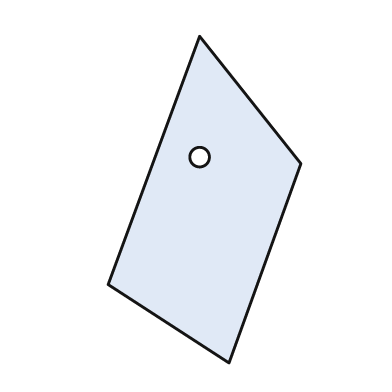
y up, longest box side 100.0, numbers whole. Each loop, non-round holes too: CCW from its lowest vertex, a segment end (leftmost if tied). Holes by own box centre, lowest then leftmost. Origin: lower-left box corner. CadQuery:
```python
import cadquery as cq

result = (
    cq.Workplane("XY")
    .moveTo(37.0, 0.0)
    .lineTo(59.0, 61.0)
    .lineTo(28.0, 100.0)
    .lineTo(0.0, 24.0)
    .close()
    .moveTo(28.0, 63.0)
    .circle(3.0)
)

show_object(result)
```